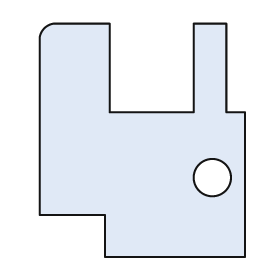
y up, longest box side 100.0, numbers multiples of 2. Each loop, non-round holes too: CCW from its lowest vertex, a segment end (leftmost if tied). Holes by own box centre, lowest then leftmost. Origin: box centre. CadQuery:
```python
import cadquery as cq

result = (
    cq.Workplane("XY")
    .moveTo(-16.0, -50.0)
    .lineTo(44.0, -50.0)
    .lineTo(44.0, 12.0)
    .lineTo(36.0, 12.0)
    .lineTo(36.0, 50.0)
    .lineTo(22.0, 50.0)
    .lineTo(22.0, 12.0)
    .lineTo(-14.0, 12.0)
    .lineTo(-14.0, 50.0)
    .lineTo(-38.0, 50.0)
    .threePointArc((-42.0, 48.0), (-44.0, 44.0))
    .lineTo(-44.0, -32.0)
    .lineTo(-16.0, -32.0)
    .close()
    .moveTo(30.0, -16.0)
    .circle(8.0)
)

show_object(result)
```